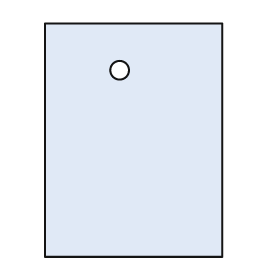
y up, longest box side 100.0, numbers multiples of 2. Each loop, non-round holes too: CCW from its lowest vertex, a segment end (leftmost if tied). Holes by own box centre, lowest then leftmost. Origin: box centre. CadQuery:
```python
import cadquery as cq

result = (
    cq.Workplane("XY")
    .moveTo(-38.0, -50.0)
    .lineTo(38.0, -50.0)
    .lineTo(38.0, 50.0)
    .lineTo(-38.0, 50.0)
    .close()
    .moveTo(-6.0, 30.0)
    .circle(4.0)
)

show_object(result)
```